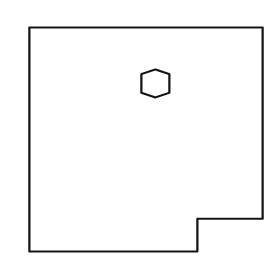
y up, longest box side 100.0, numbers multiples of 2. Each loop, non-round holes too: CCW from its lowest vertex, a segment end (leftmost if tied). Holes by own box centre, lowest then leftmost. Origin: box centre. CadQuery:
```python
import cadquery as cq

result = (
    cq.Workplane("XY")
    .moveTo(-50.0, -48.0)
    .lineTo(22.0, -48.0)
    .lineTo(22.0, -34.0)
    .lineTo(50.0, -34.0)
    .lineTo(50.0, 48.0)
    .lineTo(-50.0, 48.0)
    .close()
    .moveTo(4.0, 18.0)
    .lineTo(10.0, 20.0)
    .lineTo(10.0, 28.0)
    .lineTo(4.0, 30.0)
    .lineTo(-2.0, 28.0)
    .lineTo(-2.0, 20.0)
    .close()
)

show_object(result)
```